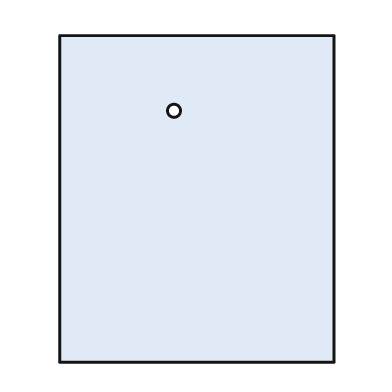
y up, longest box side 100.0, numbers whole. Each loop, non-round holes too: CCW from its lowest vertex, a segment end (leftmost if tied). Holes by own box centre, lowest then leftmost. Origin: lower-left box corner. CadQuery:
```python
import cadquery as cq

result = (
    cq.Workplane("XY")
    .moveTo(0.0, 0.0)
    .lineTo(84.0, 0.0)
    .lineTo(84.0, 100.0)
    .lineTo(0.0, 100.0)
    .close()
    .moveTo(35.0, 77.0)
    .circle(2.0)
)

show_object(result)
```